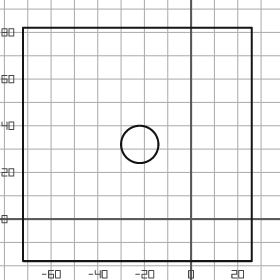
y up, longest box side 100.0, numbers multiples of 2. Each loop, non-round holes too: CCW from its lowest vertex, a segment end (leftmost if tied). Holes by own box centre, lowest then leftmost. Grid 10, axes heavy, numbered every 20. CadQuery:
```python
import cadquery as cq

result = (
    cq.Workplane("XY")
    .moveTo(-72.0, -18.0)
    .lineTo(26.0, -18.0)
    .lineTo(26.0, 82.0)
    .lineTo(-72.0, 82.0)
    .close()
    .moveTo(-22.0, 32.0)
    .circle(8.0)
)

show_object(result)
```